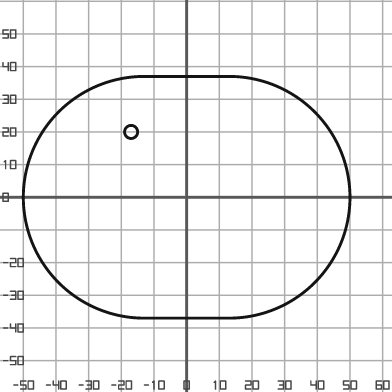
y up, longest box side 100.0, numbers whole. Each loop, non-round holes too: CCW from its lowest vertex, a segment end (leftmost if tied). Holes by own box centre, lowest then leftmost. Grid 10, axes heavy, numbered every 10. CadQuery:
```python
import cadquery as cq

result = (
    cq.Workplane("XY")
    .moveTo(-13.0, -37.0)
    .lineTo(13.0, -37.0)
    .threePointArc((50.0, 0.0), (13.0, 37.0))
    .lineTo(-13.0, 37.0)
    .threePointArc((-50.0, 0.0), (-13.0, -37.0))
    .close()
    .moveTo(-17.0, 20.0)
    .circle(2.0)
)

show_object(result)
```